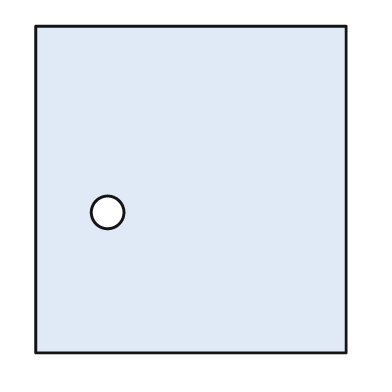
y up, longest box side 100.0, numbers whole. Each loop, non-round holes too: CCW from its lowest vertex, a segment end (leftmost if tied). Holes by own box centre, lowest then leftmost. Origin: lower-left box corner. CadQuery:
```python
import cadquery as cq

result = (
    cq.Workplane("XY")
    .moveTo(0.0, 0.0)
    .lineTo(95.0, 0.0)
    .lineTo(95.0, 100.0)
    .lineTo(0.0, 100.0)
    .close()
    .moveTo(22.0, 43.0)
    .circle(5.0)
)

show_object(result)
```